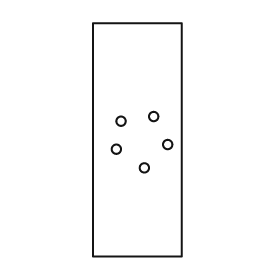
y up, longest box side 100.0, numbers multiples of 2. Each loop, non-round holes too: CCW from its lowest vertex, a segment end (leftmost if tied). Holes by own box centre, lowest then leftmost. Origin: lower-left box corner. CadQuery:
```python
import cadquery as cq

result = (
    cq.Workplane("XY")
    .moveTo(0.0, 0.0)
    .lineTo(38.0, 0.0)
    .lineTo(38.0, 100.0)
    .lineTo(0.0, 100.0)
    .close()
    .moveTo(22.0, 38.0)
    .circle(2.0)
    .moveTo(10.0, 46.0)
    .circle(2.0)
    .moveTo(32.0, 48.0)
    .circle(2.0)
    .moveTo(12.0, 58.0)
    .circle(2.0)
    .moveTo(26.0, 60.0)
    .circle(2.0)
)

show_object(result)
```